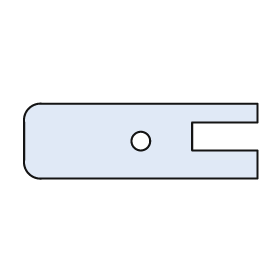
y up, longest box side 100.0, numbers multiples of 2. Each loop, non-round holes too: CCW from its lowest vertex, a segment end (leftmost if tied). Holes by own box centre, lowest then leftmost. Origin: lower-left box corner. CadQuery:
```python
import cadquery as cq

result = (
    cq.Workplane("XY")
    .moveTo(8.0, 0.0)
    .lineTo(100.0, 0.0)
    .lineTo(100.0, 12.0)
    .lineTo(72.0, 12.0)
    .lineTo(72.0, 24.0)
    .lineTo(100.0, 24.0)
    .lineTo(100.0, 32.0)
    .lineTo(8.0, 32.0)
    .threePointArc((2.0, 30.0), (0.0, 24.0))
    .lineTo(0.0, 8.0)
    .threePointArc((2.0, 2.0), (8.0, 0.0))
    .close()
    .moveTo(50.0, 16.0)
    .circle(4.0)
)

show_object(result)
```